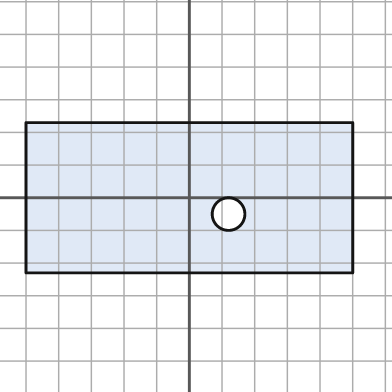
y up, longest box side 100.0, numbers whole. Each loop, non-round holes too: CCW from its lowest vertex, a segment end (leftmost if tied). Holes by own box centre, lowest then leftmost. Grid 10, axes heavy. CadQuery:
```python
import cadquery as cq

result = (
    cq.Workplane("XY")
    .moveTo(-50.0, -23.0)
    .lineTo(50.0, -23.0)
    .lineTo(50.0, 23.0)
    .lineTo(-50.0, 23.0)
    .close()
    .moveTo(12.0, -5.0)
    .circle(5.0)
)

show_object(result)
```